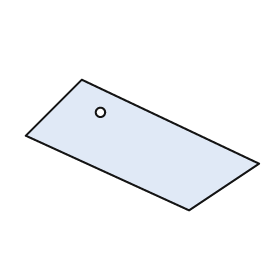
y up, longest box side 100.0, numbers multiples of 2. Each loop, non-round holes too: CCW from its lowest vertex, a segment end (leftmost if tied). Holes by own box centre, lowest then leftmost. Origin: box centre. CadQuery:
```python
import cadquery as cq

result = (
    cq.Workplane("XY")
    .moveTo(20.0, -28.0)
    .lineTo(50.0, -8.0)
    .lineTo(-26.0, 28.0)
    .lineTo(-50.0, 4.0)
    .close()
    .moveTo(-18.0, 14.0)
    .circle(2.0)
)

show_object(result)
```